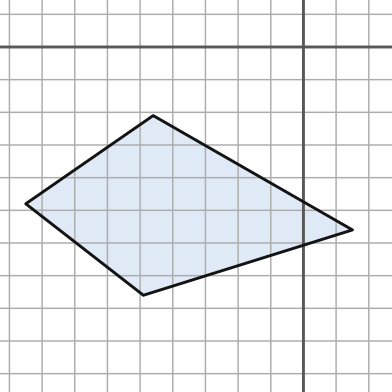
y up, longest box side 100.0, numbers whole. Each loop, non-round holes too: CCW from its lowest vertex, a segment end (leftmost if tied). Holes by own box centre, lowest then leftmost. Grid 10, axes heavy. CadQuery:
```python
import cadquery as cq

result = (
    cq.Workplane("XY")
    .moveTo(-49.0, -76.0)
    .lineTo(15.0, -56.0)
    .lineTo(-46.0, -21.0)
    .lineTo(-85.0, -48.0)
    .close()
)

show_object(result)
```